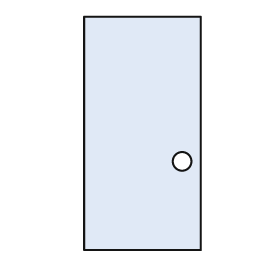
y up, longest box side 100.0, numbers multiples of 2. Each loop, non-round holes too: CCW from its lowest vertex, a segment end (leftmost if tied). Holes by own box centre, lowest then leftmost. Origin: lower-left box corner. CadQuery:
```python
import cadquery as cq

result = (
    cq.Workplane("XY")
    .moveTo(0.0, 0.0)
    .lineTo(50.0, 0.0)
    .lineTo(50.0, 100.0)
    .lineTo(0.0, 100.0)
    .close()
    .moveTo(42.0, 38.0)
    .circle(4.0)
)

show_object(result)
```